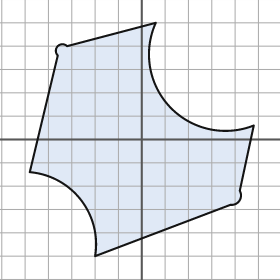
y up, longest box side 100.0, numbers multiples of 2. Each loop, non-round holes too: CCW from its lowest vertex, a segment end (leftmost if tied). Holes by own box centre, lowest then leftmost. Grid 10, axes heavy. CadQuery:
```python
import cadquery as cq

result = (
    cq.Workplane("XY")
    .moveTo(-20.0, -50.0)
    .lineTo(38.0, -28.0)
    .threePointArc((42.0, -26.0), (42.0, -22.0))
    .lineTo(48.0, 6.0)
    .threePointArc((12.0, 14.0), (6.0, 50.0))
    .lineTo(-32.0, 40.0)
    .threePointArc((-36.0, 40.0), (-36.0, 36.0))
    .lineTo(-48.0, -14.0)
    .threePointArc((-26.0, -26.0), (-20.0, -50.0))
    .close()
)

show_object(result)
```